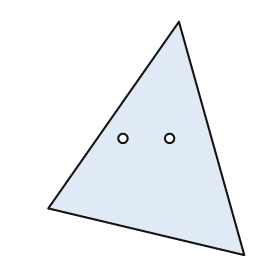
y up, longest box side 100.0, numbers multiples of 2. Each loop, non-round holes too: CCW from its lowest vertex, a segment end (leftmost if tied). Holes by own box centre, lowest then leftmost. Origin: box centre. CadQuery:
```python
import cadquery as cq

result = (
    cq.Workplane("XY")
    .moveTo(42.0, -50.0)
    .lineTo(14.0, 50.0)
    .lineTo(-42.0, -30.0)
    .close()
    .moveTo(-10.0, 0.0)
    .circle(2.0)
    .moveTo(10.0, 0.0)
    .circle(2.0)
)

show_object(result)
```